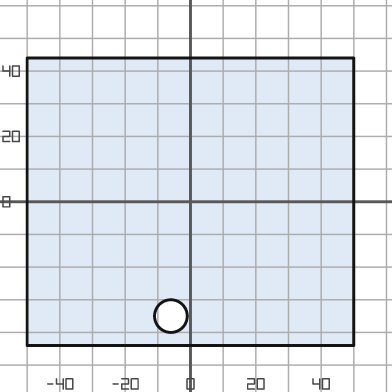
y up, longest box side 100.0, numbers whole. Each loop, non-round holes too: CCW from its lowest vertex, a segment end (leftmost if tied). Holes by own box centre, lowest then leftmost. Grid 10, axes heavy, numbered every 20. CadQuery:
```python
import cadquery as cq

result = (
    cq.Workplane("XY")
    .moveTo(-50.0, -44.0)
    .lineTo(50.0, -44.0)
    .lineTo(50.0, 44.0)
    .lineTo(-50.0, 44.0)
    .close()
    .moveTo(-6.0, -35.0)
    .circle(5.0)
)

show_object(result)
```